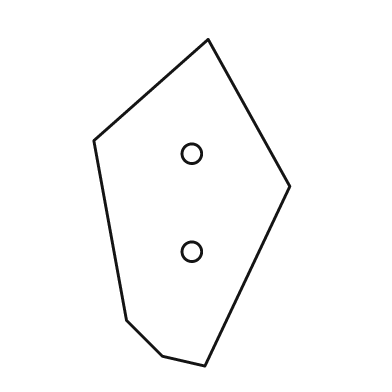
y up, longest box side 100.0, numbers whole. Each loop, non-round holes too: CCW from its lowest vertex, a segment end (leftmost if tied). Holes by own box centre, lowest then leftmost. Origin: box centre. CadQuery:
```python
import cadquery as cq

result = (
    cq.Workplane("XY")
    .moveTo(4.0, -50.0)
    .lineTo(30.0, 5.0)
    .lineTo(5.0, 50.0)
    .lineTo(-30.0, 19.0)
    .lineTo(-20.0, -36.0)
    .lineTo(-9.0, -47.0)
    .close()
    .moveTo(0.0, -15.0)
    .circle(3.0)
    .moveTo(0.0, 15.0)
    .circle(3.0)
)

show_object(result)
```